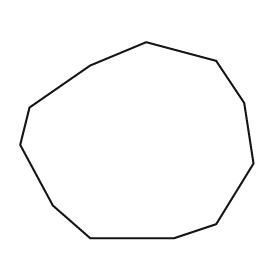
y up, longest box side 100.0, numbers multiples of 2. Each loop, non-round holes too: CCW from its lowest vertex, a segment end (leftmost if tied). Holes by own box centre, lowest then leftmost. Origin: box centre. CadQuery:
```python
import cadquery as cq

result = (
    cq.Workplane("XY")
    .moveTo(-20.0, -42.0)
    .lineTo(16.0, -42.0)
    .lineTo(34.0, -36.0)
    .lineTo(50.0, -10.0)
    .lineTo(46.0, 16.0)
    .lineTo(34.0, 34.0)
    .lineTo(4.0, 42.0)
    .lineTo(-20.0, 32.0)
    .lineTo(-46.0, 14.0)
    .lineTo(-50.0, -2.0)
    .lineTo(-36.0, -28.0)
    .close()
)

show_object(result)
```